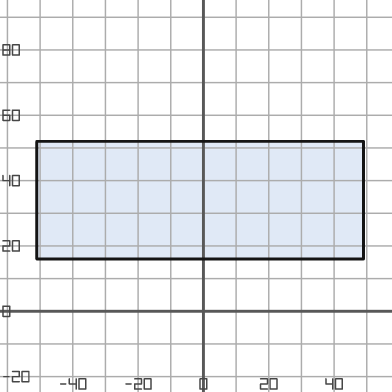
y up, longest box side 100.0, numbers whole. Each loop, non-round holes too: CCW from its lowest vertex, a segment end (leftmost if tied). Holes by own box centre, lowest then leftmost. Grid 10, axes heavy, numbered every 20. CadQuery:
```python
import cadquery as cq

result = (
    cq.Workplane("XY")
    .moveTo(-51.0, 16.0)
    .lineTo(49.0, 16.0)
    .lineTo(49.0, 52.0)
    .lineTo(-51.0, 52.0)
    .close()
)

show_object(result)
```